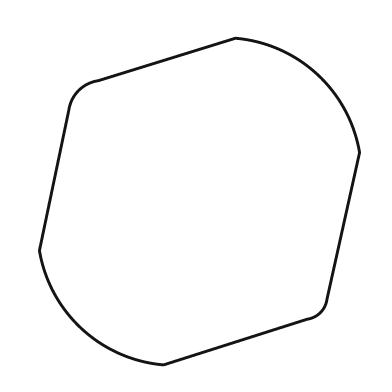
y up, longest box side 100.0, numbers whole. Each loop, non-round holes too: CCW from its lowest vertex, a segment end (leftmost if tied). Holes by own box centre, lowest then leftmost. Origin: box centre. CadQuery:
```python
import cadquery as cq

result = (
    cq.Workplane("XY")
    .moveTo(-11.0, -50.0)
    .lineTo(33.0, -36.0)
    .threePointArc((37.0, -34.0), (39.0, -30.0))
    .lineTo(49.0, 15.0)
    .threePointArc((36.0, 39.0), (11.0, 50.0))
    .lineTo(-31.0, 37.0)
    .threePointArc((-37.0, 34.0), (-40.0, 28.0))
    .lineTo(-49.0, -15.0)
    .threePointArc((-36.0, -39.0), (-11.0, -50.0))
    .close()
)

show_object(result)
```